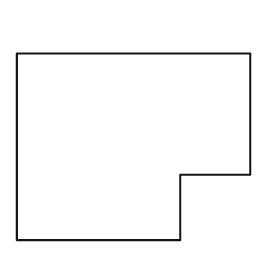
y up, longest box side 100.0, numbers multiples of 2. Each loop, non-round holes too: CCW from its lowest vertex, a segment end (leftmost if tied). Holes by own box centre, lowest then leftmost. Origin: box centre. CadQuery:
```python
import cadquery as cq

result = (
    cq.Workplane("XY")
    .moveTo(-50.0, -40.0)
    .lineTo(20.0, -40.0)
    .lineTo(20.0, -12.0)
    .lineTo(50.0, -12.0)
    .lineTo(50.0, 40.0)
    .lineTo(-50.0, 40.0)
    .close()
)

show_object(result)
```